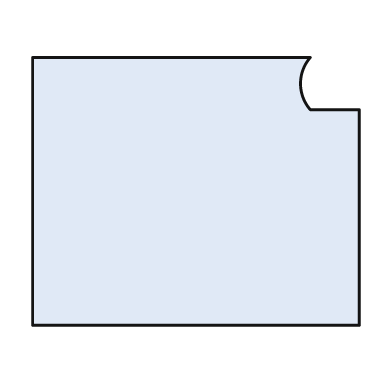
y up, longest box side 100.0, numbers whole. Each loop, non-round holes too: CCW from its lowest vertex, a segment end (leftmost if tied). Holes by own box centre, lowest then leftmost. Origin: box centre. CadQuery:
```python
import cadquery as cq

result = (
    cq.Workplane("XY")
    .moveTo(-50.0, -41.0)
    .lineTo(50.0, -41.0)
    .lineTo(50.0, 25.0)
    .lineTo(35.0, 25.0)
    .threePointArc((32.0, 33.0), (35.0, 41.0))
    .lineTo(-50.0, 41.0)
    .close()
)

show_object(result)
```